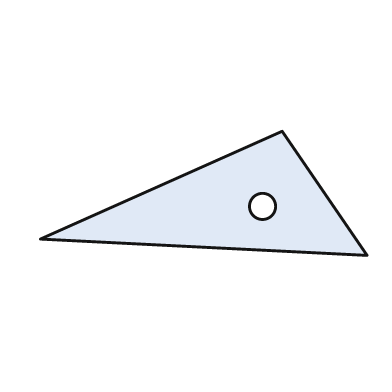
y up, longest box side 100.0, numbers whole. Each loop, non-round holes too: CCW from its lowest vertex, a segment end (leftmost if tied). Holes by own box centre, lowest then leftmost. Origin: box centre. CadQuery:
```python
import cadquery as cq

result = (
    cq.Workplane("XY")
    .moveTo(50.0, -19.0)
    .lineTo(24.0, 19.0)
    .lineTo(-50.0, -14.0)
    .close()
    .moveTo(18.0, -4.0)
    .circle(4.0)
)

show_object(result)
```